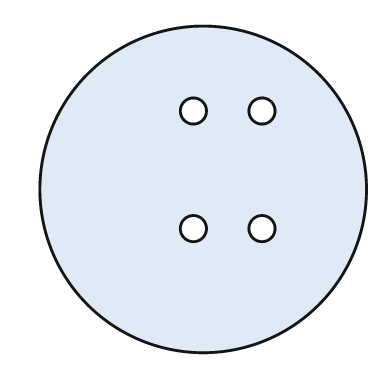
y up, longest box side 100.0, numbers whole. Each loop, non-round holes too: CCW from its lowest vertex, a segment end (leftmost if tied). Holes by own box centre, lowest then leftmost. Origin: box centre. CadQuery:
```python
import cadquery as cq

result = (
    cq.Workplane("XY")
    .moveTo(0.0, 0.0)
    .circle(50.0)
    .moveTo(-3.0, -12.0)
    .circle(4.0)
    .moveTo(18.0, -12.0)
    .circle(4.0)
    .moveTo(-3.0, 24.0)
    .circle(4.0)
    .moveTo(18.0, 24.0)
    .circle(4.0)
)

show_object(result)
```